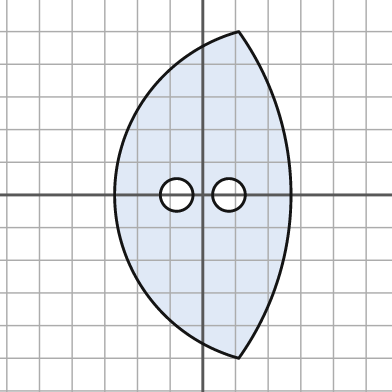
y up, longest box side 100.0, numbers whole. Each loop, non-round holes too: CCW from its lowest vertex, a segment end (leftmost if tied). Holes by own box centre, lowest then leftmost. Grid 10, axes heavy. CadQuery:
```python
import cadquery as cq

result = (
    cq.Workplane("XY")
    .moveTo(11.0, -50.0)
    .threePointArc((27.0, 0.0), (11.0, 50.0))
    .threePointArc((-27.0, 0.0), (11.0, -50.0))
    .close()
    .moveTo(-8.0, 0.0)
    .circle(5.0)
    .moveTo(8.0, 0.0)
    .circle(5.0)
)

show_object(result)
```